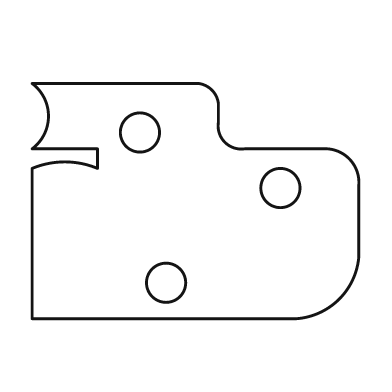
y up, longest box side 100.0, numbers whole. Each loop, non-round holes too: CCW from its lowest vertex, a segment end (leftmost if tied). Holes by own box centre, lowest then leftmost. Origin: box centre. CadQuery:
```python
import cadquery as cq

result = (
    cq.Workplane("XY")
    .moveTo(-50.0, -36.0)
    .lineTo(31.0, -36.0)
    .threePointArc((44.0, -30.0), (50.0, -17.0))
    .lineTo(50.0, 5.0)
    .threePointArc((47.0, 13.0), (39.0, 16.0))
    .lineTo(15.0, 16.0)
    .threePointArc((9.0, 18.0), (7.0, 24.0))
    .lineTo(7.0, 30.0)
    .threePointArc((5.0, 34.0), (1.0, 36.0))
    .lineTo(-50.0, 36.0)
    .threePointArc((-45.0, 26.0), (-50.0, 16.0))
    .lineTo(-30.0, 16.0)
    .lineTo(-30.0, 10.0)
    .threePointArc((-40.0, 12.0), (-50.0, 10.0))
    .close()
    .moveTo(-9.0, -25.0)
    .circle(6.0)
    .moveTo(26.0, 4.0)
    .circle(6.0)
    .moveTo(-17.0, 21.0)
    .circle(6.0)
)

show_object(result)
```